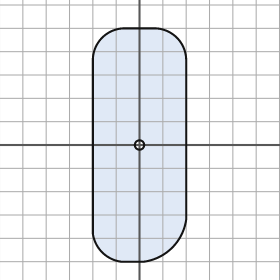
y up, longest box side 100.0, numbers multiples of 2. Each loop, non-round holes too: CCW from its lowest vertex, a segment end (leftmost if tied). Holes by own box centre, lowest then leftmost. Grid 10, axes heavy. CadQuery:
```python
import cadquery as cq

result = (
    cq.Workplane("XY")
    .moveTo(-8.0, -50.0)
    .lineTo(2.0, -50.0)
    .threePointArc((14.0, -44.0), (20.0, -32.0))
    .lineTo(20.0, 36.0)
    .threePointArc((16.0, 46.0), (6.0, 50.0))
    .lineTo(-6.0, 50.0)
    .threePointArc((-16.0, 46.0), (-20.0, 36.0))
    .lineTo(-20.0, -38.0)
    .threePointArc((-16.0, -46.0), (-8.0, -50.0))
    .close()
    .moveTo(0.0, 0.0)
    .circle(2.0)
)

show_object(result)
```